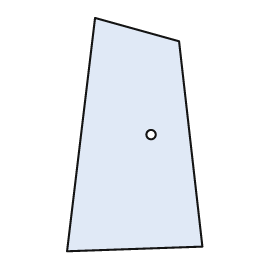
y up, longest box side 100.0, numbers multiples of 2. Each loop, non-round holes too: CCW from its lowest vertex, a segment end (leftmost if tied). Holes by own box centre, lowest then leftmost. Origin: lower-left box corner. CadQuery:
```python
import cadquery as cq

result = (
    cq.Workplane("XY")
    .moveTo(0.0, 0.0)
    .lineTo(58.0, 2.0)
    .lineTo(48.0, 90.0)
    .lineTo(12.0, 100.0)
    .close()
    .moveTo(36.0, 50.0)
    .circle(2.0)
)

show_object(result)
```